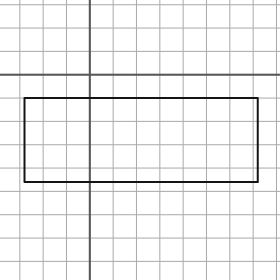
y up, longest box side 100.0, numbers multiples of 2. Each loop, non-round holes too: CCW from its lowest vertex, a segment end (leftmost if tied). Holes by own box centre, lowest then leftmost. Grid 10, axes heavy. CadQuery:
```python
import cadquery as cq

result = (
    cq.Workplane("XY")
    .moveTo(-28.0, -46.0)
    .lineTo(72.0, -46.0)
    .lineTo(72.0, -10.0)
    .lineTo(-28.0, -10.0)
    .close()
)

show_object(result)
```